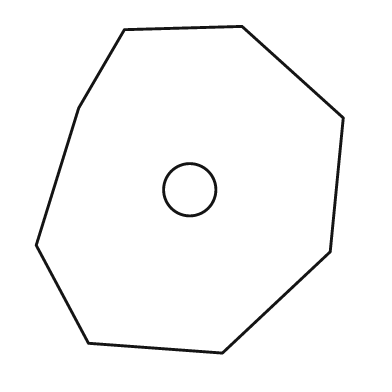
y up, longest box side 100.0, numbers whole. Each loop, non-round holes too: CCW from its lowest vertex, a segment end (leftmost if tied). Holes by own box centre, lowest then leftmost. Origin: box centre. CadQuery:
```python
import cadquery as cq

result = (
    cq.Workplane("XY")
    .moveTo(10.0, -50.0)
    .lineTo(43.0, -19.0)
    .lineTo(47.0, 22.0)
    .lineTo(16.0, 50.0)
    .lineTo(-20.0, 49.0)
    .lineTo(-34.0, 25.0)
    .lineTo(-47.0, -17.0)
    .lineTo(-31.0, -47.0)
    .close()
    .moveTo(0.0, 0.0)
    .circle(8.0)
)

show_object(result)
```